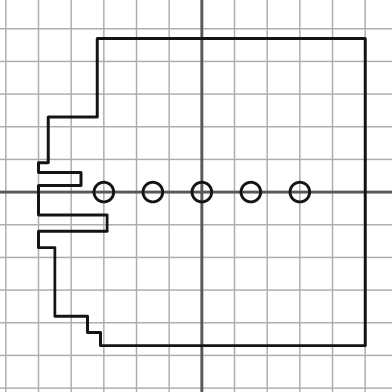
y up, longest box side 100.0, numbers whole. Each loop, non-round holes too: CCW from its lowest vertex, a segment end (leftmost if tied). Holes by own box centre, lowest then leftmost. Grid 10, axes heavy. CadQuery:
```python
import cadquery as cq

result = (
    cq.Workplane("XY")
    .moveTo(-31.0, -47.0)
    .lineTo(50.0, -47.0)
    .lineTo(50.0, 47.0)
    .lineTo(-32.0, 47.0)
    .lineTo(-32.0, 23.0)
    .lineTo(-47.0, 23.0)
    .lineTo(-47.0, 9.0)
    .lineTo(-50.0, 9.0)
    .lineTo(-50.0, 6.0)
    .lineTo(-37.0, 6.0)
    .lineTo(-37.0, 2.0)
    .lineTo(-50.0, 2.0)
    .lineTo(-50.0, -7.0)
    .lineTo(-29.0, -7.0)
    .lineTo(-29.0, -12.0)
    .lineTo(-50.0, -12.0)
    .lineTo(-50.0, -17.0)
    .lineTo(-45.0, -17.0)
    .lineTo(-45.0, -38.0)
    .lineTo(-35.0, -38.0)
    .lineTo(-35.0, -43.0)
    .lineTo(-31.0, -43.0)
    .close()
    .moveTo(-30.0, 0.0)
    .circle(3.0)
    .moveTo(-15.0, 0.0)
    .circle(3.0)
    .moveTo(0.0, 0.0)
    .circle(3.0)
    .moveTo(15.0, 0.0)
    .circle(3.0)
    .moveTo(30.0, 0.0)
    .circle(3.0)
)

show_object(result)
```